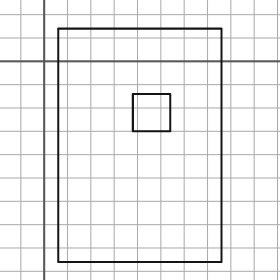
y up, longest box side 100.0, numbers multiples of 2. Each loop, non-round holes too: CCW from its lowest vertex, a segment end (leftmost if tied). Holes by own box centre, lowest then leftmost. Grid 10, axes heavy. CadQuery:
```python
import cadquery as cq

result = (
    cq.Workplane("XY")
    .moveTo(6.0, -86.0)
    .lineTo(76.0, -86.0)
    .lineTo(76.0, 14.0)
    .lineTo(6.0, 14.0)
    .close()
    .moveTo(38.0, -30.0)
    .lineTo(54.0, -30.0)
    .lineTo(54.0, -14.0)
    .lineTo(38.0, -14.0)
    .close()
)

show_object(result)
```